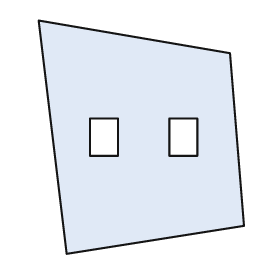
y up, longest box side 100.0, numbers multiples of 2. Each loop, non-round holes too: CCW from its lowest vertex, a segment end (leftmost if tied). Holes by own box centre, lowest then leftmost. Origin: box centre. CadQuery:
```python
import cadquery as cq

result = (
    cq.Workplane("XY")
    .moveTo(-32.0, -50.0)
    .lineTo(44.0, -38.0)
    .lineTo(38.0, 36.0)
    .lineTo(-44.0, 50.0)
    .close()
    .moveTo(-22.0, -8.0)
    .lineTo(-10.0, -8.0)
    .lineTo(-10.0, 8.0)
    .lineTo(-22.0, 8.0)
    .close()
    .moveTo(12.0, -8.0)
    .lineTo(24.0, -8.0)
    .lineTo(24.0, 8.0)
    .lineTo(12.0, 8.0)
    .close()
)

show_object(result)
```